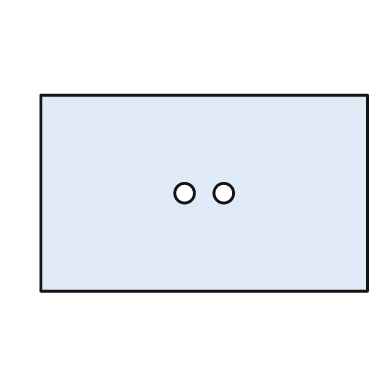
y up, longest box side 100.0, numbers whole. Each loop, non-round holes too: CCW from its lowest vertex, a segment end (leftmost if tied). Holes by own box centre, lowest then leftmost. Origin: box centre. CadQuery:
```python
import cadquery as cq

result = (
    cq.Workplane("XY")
    .moveTo(-50.0, -30.0)
    .lineTo(50.0, -30.0)
    .lineTo(50.0, 30.0)
    .lineTo(-50.0, 30.0)
    .close()
    .moveTo(-6.0, 0.0)
    .circle(3.0)
    .moveTo(6.0, 0.0)
    .circle(3.0)
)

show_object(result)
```